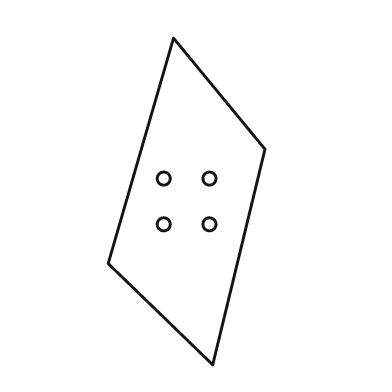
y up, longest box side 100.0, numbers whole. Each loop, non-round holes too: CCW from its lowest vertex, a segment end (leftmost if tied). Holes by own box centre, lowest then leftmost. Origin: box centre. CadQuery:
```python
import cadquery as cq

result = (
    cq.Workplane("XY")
    .moveTo(8.0, -50.0)
    .lineTo(24.0, 16.0)
    .lineTo(-4.0, 50.0)
    .lineTo(-24.0, -19.0)
    .close()
    .moveTo(-7.0, -7.0)
    .circle(2.0)
    .moveTo(7.0, -7.0)
    .circle(2.0)
    .moveTo(-7.0, 7.0)
    .circle(2.0)
    .moveTo(7.0, 7.0)
    .circle(2.0)
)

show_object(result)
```